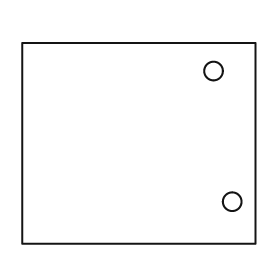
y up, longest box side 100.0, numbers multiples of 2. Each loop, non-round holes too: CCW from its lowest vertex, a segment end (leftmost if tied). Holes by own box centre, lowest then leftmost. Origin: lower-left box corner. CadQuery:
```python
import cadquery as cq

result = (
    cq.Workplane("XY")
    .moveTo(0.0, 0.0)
    .lineTo(100.0, 0.0)
    .lineTo(100.0, 86.0)
    .lineTo(0.0, 86.0)
    .close()
    .moveTo(90.0, 18.0)
    .circle(4.0)
    .moveTo(82.0, 74.0)
    .circle(4.0)
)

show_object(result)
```